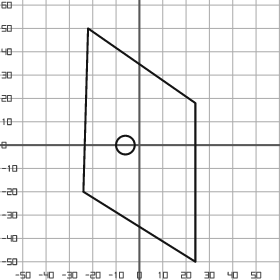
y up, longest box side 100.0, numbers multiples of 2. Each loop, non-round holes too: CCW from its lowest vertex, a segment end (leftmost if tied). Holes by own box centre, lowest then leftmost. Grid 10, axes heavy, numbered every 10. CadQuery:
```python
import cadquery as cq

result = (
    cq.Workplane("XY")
    .moveTo(24.0, -50.0)
    .lineTo(24.0, 18.0)
    .lineTo(-22.0, 50.0)
    .lineTo(-24.0, -20.0)
    .close()
    .moveTo(-6.0, 0.0)
    .circle(4.0)
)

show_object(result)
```